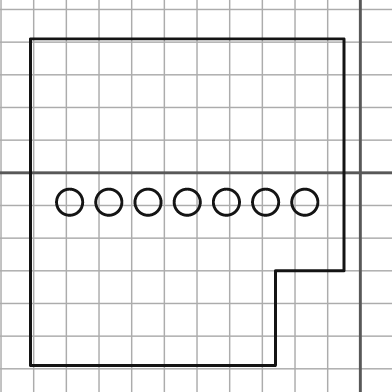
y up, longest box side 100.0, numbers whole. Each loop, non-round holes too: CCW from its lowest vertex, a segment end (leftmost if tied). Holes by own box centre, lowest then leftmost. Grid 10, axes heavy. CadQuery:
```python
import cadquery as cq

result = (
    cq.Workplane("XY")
    .moveTo(-101.0, -59.0)
    .lineTo(-26.0, -59.0)
    .lineTo(-26.0, -30.0)
    .lineTo(-5.0, -30.0)
    .lineTo(-5.0, 41.0)
    .lineTo(-101.0, 41.0)
    .close()
    .moveTo(-89.0, -9.0)
    .circle(4.0)
    .moveTo(-77.0, -9.0)
    .circle(4.0)
    .moveTo(-65.0, -9.0)
    .circle(4.0)
    .moveTo(-53.0, -9.0)
    .circle(4.0)
    .moveTo(-41.0, -9.0)
    .circle(4.0)
    .moveTo(-29.0, -9.0)
    .circle(4.0)
    .moveTo(-17.0, -9.0)
    .circle(4.0)
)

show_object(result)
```